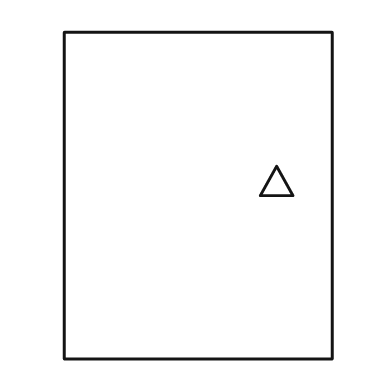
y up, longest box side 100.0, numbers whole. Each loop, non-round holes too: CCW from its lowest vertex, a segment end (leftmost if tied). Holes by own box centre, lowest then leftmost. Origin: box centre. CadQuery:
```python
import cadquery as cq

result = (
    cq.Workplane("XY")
    .moveTo(-41.0, -50.0)
    .lineTo(41.0, -50.0)
    .lineTo(41.0, 50.0)
    .lineTo(-41.0, 50.0)
    .close()
    .moveTo(19.0, 0.0)
    .lineTo(29.0, 0.0)
    .lineTo(24.0, 9.0)
    .close()
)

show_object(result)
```